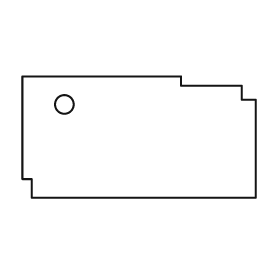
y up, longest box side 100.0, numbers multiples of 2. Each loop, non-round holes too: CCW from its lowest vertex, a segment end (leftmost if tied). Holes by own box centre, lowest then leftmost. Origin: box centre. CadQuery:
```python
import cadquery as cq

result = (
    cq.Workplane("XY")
    .moveTo(-46.0, -26.0)
    .lineTo(50.0, -26.0)
    .lineTo(50.0, 16.0)
    .lineTo(44.0, 16.0)
    .lineTo(44.0, 22.0)
    .lineTo(18.0, 22.0)
    .lineTo(18.0, 26.0)
    .lineTo(-50.0, 26.0)
    .lineTo(-50.0, -18.0)
    .lineTo(-46.0, -18.0)
    .close()
    .moveTo(-32.0, 14.0)
    .circle(4.0)
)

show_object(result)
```